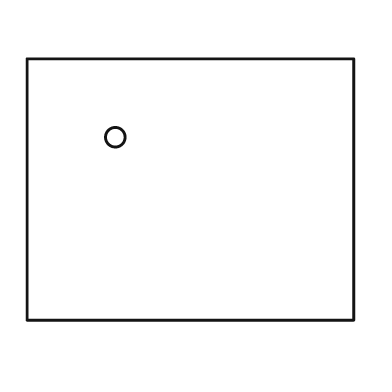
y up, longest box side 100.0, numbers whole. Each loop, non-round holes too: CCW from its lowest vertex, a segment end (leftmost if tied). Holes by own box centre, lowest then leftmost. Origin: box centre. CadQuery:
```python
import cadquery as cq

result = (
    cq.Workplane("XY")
    .moveTo(-50.0, -40.0)
    .lineTo(50.0, -40.0)
    .lineTo(50.0, 40.0)
    .lineTo(-50.0, 40.0)
    .close()
    .moveTo(-23.0, 16.0)
    .circle(3.0)
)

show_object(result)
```